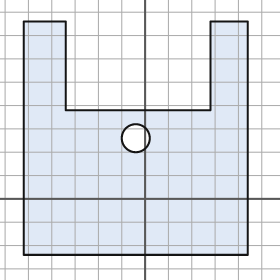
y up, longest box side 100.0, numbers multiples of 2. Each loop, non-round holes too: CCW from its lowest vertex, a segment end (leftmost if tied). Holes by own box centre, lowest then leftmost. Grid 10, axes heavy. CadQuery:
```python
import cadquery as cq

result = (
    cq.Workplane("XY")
    .moveTo(-52.0, -24.0)
    .lineTo(44.0, -24.0)
    .lineTo(44.0, 76.0)
    .lineTo(28.0, 76.0)
    .lineTo(28.0, 38.0)
    .lineTo(-34.0, 38.0)
    .lineTo(-34.0, 76.0)
    .lineTo(-52.0, 76.0)
    .close()
    .moveTo(-4.0, 26.0)
    .circle(6.0)
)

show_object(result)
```